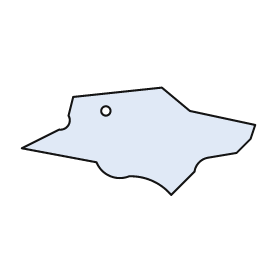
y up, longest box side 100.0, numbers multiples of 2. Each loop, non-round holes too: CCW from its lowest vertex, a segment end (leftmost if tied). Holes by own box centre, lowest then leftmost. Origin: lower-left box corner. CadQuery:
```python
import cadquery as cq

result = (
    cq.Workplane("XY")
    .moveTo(64.0, 0.0)
    .lineTo(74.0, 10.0)
    .threePointArc((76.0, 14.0), (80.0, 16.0))
    .lineTo(92.0, 18.0)
    .lineTo(98.0, 24.0)
    .lineTo(100.0, 30.0)
    .lineTo(72.0, 36.0)
    .lineTo(60.0, 46.0)
    .lineTo(22.0, 42.0)
    .lineTo(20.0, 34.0)
    .threePointArc((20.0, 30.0), (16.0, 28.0))
    .lineTo(0.0, 20.0)
    .lineTo(32.0, 14.0)
    .threePointArc((38.0, 8.0), (46.0, 8.0))
    .threePointArc((56.0, 6.0), (64.0, 0.0))
    .close()
    .moveTo(36.0, 36.0)
    .circle(2.0)
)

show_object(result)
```